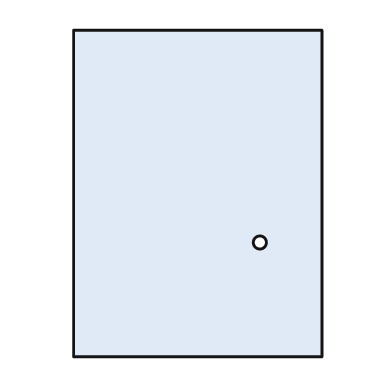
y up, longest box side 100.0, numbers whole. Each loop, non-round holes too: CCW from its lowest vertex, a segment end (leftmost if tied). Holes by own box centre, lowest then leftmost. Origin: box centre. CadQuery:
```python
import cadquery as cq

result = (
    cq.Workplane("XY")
    .moveTo(-38.0, -50.0)
    .lineTo(38.0, -50.0)
    .lineTo(38.0, 50.0)
    .lineTo(-38.0, 50.0)
    .close()
    .moveTo(19.0, -15.0)
    .circle(2.0)
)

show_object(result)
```